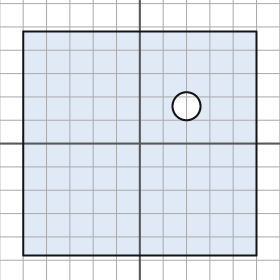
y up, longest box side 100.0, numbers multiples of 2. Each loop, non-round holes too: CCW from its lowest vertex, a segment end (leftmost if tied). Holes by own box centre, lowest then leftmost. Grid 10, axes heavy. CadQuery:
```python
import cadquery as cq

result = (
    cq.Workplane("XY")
    .moveTo(-50.0, -48.0)
    .lineTo(50.0, -48.0)
    .lineTo(50.0, 48.0)
    .lineTo(-50.0, 48.0)
    .close()
    .moveTo(20.0, 16.0)
    .circle(6.0)
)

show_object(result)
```